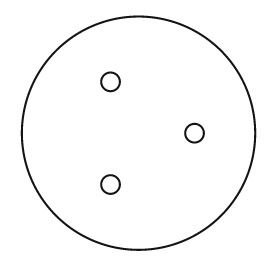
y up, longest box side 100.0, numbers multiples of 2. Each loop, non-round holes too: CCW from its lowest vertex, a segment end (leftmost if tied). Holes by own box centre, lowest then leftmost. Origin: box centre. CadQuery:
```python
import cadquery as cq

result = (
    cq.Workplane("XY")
    .moveTo(0.0, 0.0)
    .circle(50.0)
    .moveTo(-12.0, -22.0)
    .circle(4.0)
    .moveTo(24.0, 0.0)
    .circle(4.0)
    .moveTo(-12.0, 22.0)
    .circle(4.0)
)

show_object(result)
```